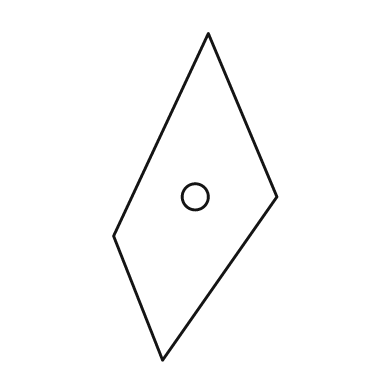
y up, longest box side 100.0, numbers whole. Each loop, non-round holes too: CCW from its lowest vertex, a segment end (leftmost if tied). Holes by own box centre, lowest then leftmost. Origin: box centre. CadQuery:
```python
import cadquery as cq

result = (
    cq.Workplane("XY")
    .moveTo(-10.0, -50.0)
    .lineTo(25.0, 0.0)
    .lineTo(4.0, 50.0)
    .lineTo(-25.0, -12.0)
    .close()
    .moveTo(0.0, 0.0)
    .circle(4.0)
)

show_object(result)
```